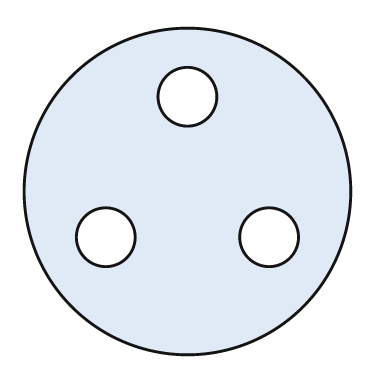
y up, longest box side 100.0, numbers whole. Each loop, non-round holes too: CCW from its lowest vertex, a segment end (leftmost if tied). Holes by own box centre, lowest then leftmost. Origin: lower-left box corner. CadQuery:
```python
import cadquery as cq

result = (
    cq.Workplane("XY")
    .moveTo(50.0, 50.0)
    .circle(50.0)
    .moveTo(25.0, 36.0)
    .circle(9.0)
    .moveTo(75.0, 36.0)
    .circle(9.0)
    .moveTo(50.0, 79.0)
    .circle(9.0)
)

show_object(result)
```